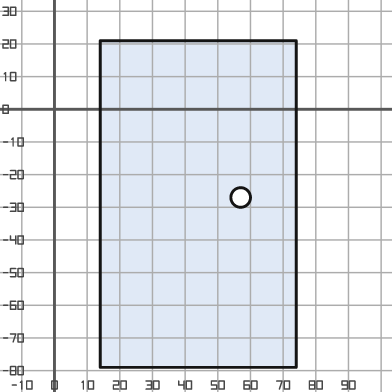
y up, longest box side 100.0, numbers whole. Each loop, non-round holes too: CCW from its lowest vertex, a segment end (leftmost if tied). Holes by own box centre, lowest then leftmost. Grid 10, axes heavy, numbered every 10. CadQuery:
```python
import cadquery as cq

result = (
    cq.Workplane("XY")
    .moveTo(14.0, -79.0)
    .lineTo(74.0, -79.0)
    .lineTo(74.0, 21.0)
    .lineTo(14.0, 21.0)
    .close()
    .moveTo(57.0, -27.0)
    .circle(3.0)
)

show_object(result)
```